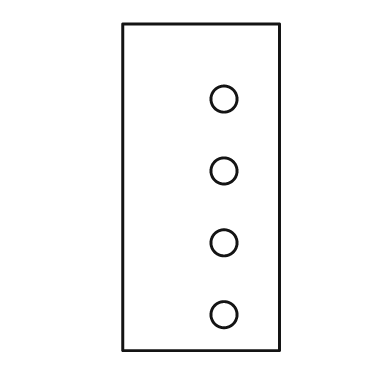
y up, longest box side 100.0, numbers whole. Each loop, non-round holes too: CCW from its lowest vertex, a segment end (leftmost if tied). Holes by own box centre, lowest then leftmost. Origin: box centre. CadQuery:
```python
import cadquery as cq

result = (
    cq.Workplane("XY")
    .moveTo(-24.0, -50.0)
    .lineTo(24.0, -50.0)
    .lineTo(24.0, 50.0)
    .lineTo(-24.0, 50.0)
    .close()
    .moveTo(7.0, -39.0)
    .circle(4.0)
    .moveTo(7.0, -17.0)
    .circle(4.0)
    .moveTo(7.0, 5.0)
    .circle(4.0)
    .moveTo(7.0, 27.0)
    .circle(4.0)
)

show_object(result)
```